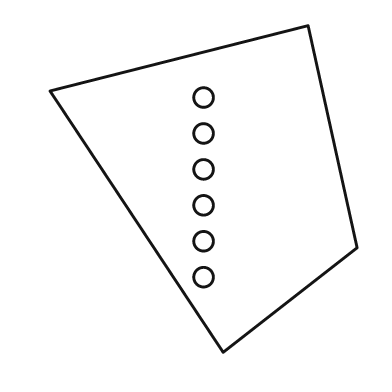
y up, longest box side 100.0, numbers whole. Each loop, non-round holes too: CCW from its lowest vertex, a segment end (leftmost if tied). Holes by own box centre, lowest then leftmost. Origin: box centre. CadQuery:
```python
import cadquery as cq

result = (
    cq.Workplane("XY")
    .moveTo(6.0, -50.0)
    .lineTo(47.0, -18.0)
    .lineTo(32.0, 50.0)
    .lineTo(-47.0, 30.0)
    .close()
    .moveTo(0.0, -27.0)
    .circle(3.0)
    .moveTo(0.0, -16.0)
    .circle(3.0)
    .moveTo(0.0, -5.0)
    .circle(3.0)
    .moveTo(0.0, 6.0)
    .circle(3.0)
    .moveTo(0.0, 17.0)
    .circle(3.0)
    .moveTo(0.0, 28.0)
    .circle(3.0)
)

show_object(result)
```